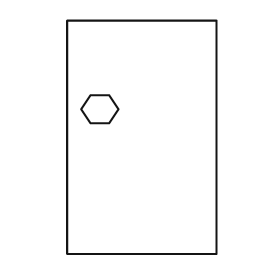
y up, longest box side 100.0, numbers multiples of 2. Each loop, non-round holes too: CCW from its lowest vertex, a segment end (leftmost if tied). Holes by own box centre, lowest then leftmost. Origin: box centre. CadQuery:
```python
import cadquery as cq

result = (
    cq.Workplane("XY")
    .moveTo(-32.0, -50.0)
    .lineTo(32.0, -50.0)
    .lineTo(32.0, 50.0)
    .lineTo(-32.0, 50.0)
    .close()
    .moveTo(-22.0, 6.0)
    .lineTo(-14.0, 6.0)
    .lineTo(-10.0, 12.0)
    .lineTo(-14.0, 18.0)
    .lineTo(-22.0, 18.0)
    .lineTo(-26.0, 12.0)
    .close()
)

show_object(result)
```